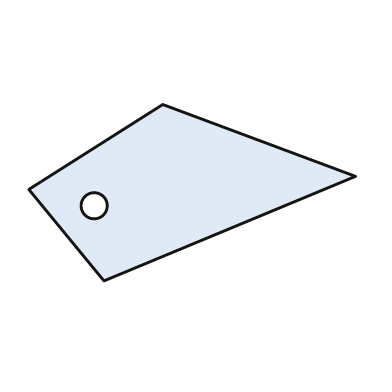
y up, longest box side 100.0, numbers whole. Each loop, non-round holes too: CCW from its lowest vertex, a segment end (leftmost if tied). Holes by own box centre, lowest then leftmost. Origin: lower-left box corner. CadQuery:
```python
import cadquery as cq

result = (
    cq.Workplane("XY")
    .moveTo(23.0, 0.0)
    .lineTo(100.0, 32.0)
    .lineTo(41.0, 54.0)
    .lineTo(0.0, 28.0)
    .close()
    .moveTo(20.0, 23.0)
    .circle(4.0)
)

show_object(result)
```